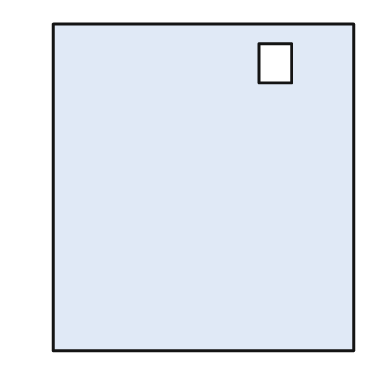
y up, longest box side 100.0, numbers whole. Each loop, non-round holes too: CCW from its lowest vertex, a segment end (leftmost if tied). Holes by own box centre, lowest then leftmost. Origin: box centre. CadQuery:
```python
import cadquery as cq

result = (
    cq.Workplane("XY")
    .moveTo(-46.0, -50.0)
    .lineTo(46.0, -50.0)
    .lineTo(46.0, 50.0)
    .lineTo(-46.0, 50.0)
    .close()
    .moveTo(17.0, 32.0)
    .lineTo(27.0, 32.0)
    .lineTo(27.0, 44.0)
    .lineTo(17.0, 44.0)
    .close()
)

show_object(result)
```